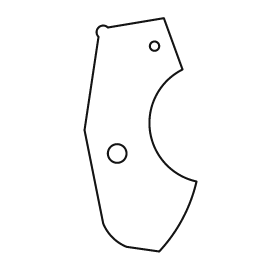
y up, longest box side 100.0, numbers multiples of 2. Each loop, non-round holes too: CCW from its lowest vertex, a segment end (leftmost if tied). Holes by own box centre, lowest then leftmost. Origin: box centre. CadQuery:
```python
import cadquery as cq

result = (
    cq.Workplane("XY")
    .moveTo(8.0, -50.0)
    .threePointArc((18.0, -36.0), (24.0, -20.0))
    .threePointArc((4.0, 2.0), (18.0, 28.0))
    .lineTo(10.0, 50.0)
    .lineTo(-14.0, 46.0)
    .threePointArc((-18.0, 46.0), (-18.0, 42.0))
    .lineTo(-24.0, 2.0)
    .lineTo(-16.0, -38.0)
    .threePointArc((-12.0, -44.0), (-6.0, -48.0))
    .close()
    .moveTo(-10.0, -8.0)
    .circle(4.0)
    .moveTo(6.0, 38.0)
    .circle(2.0)
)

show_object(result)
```